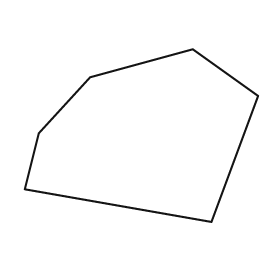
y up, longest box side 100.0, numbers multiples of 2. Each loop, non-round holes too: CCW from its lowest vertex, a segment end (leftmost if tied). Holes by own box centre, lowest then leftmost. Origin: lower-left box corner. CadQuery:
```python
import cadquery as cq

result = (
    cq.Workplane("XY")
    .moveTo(80.0, 0.0)
    .lineTo(100.0, 54.0)
    .lineTo(72.0, 74.0)
    .lineTo(28.0, 62.0)
    .lineTo(6.0, 38.0)
    .lineTo(0.0, 14.0)
    .close()
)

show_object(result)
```